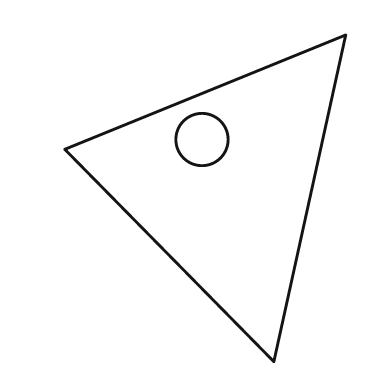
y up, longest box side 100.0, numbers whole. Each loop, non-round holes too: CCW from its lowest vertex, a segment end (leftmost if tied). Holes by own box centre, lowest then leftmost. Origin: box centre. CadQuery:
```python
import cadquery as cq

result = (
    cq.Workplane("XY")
    .moveTo(21.0, -50.0)
    .lineTo(43.0, 50.0)
    .lineTo(-43.0, 15.0)
    .close()
    .moveTo(-1.0, 18.0)
    .circle(8.0)
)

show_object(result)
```